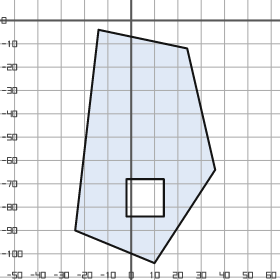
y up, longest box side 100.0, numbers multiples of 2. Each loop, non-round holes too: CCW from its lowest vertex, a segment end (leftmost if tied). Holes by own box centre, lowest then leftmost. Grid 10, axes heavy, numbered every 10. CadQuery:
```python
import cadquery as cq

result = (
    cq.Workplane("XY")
    .moveTo(10.0, -104.0)
    .lineTo(36.0, -64.0)
    .lineTo(24.0, -12.0)
    .lineTo(-14.0, -4.0)
    .lineTo(-24.0, -90.0)
    .close()
    .moveTo(-2.0, -84.0)
    .lineTo(14.0, -84.0)
    .lineTo(14.0, -68.0)
    .lineTo(-2.0, -68.0)
    .close()
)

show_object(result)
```